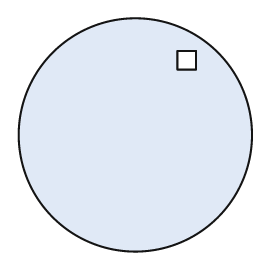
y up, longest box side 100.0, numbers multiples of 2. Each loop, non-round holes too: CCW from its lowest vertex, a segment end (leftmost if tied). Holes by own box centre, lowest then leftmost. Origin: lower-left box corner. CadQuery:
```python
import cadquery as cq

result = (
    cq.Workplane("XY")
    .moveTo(50.0, 50.0)
    .circle(50.0)
    .moveTo(68.0, 78.0)
    .lineTo(76.0, 78.0)
    .lineTo(76.0, 86.0)
    .lineTo(68.0, 86.0)
    .close()
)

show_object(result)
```